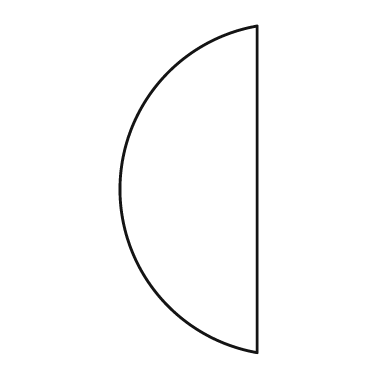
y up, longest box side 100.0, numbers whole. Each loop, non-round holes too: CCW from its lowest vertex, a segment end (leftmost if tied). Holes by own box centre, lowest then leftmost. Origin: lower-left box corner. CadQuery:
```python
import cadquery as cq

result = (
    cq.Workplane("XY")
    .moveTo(42.0, 0.0)
    .lineTo(42.0, 100.0)
    .threePointArc((0.0, 50.0), (42.0, 0.0))
    .close()
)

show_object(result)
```